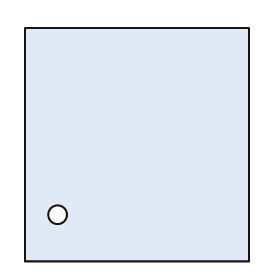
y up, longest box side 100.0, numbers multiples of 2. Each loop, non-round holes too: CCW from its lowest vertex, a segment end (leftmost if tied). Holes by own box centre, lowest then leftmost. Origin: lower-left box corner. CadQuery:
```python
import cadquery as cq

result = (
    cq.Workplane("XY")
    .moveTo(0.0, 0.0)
    .lineTo(96.0, 0.0)
    .lineTo(96.0, 100.0)
    .lineTo(0.0, 100.0)
    .close()
    .moveTo(14.0, 20.0)
    .circle(4.0)
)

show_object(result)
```